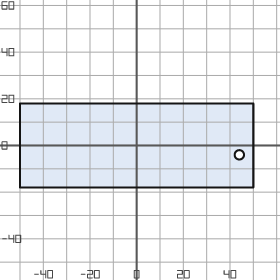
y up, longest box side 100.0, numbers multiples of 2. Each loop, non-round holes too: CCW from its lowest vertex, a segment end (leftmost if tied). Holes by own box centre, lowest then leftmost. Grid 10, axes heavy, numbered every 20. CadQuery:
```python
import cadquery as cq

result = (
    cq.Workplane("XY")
    .moveTo(-50.0, -18.0)
    .lineTo(50.0, -18.0)
    .lineTo(50.0, 18.0)
    .lineTo(-50.0, 18.0)
    .close()
    .moveTo(44.0, -4.0)
    .circle(2.0)
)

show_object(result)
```